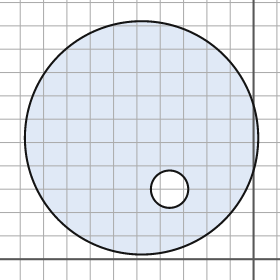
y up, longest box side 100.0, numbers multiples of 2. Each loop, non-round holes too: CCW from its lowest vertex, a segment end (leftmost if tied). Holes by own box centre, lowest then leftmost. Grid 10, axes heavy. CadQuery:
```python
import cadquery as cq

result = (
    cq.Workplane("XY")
    .moveTo(-48.0, 52.0)
    .circle(50.0)
    .moveTo(-36.0, 30.0)
    .circle(8.0)
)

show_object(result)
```